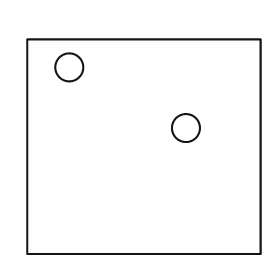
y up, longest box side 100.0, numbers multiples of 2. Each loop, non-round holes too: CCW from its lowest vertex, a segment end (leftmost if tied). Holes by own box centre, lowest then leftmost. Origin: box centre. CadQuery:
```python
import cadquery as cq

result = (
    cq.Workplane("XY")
    .moveTo(-50.0, -46.0)
    .lineTo(50.0, -46.0)
    .lineTo(50.0, 46.0)
    .lineTo(-50.0, 46.0)
    .close()
    .moveTo(18.0, 8.0)
    .circle(6.0)
    .moveTo(-32.0, 34.0)
    .circle(6.0)
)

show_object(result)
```